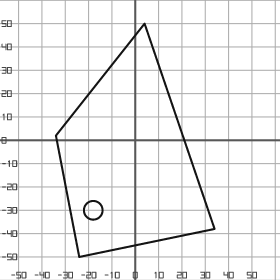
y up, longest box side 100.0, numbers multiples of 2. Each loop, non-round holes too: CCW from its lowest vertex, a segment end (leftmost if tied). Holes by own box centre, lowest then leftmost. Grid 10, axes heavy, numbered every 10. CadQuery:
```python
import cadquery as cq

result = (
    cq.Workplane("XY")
    .moveTo(-24.0, -50.0)
    .lineTo(34.0, -38.0)
    .lineTo(4.0, 50.0)
    .lineTo(-34.0, 2.0)
    .close()
    .moveTo(-18.0, -30.0)
    .circle(4.0)
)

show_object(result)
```